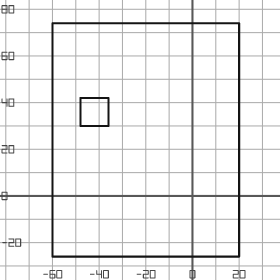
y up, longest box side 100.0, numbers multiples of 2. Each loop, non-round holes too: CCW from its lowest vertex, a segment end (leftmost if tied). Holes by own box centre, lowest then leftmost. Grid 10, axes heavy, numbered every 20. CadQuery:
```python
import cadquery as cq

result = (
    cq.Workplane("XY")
    .moveTo(-60.0, -26.0)
    .lineTo(20.0, -26.0)
    .lineTo(20.0, 74.0)
    .lineTo(-60.0, 74.0)
    .close()
    .moveTo(-48.0, 30.0)
    .lineTo(-36.0, 30.0)
    .lineTo(-36.0, 42.0)
    .lineTo(-48.0, 42.0)
    .close()
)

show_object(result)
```